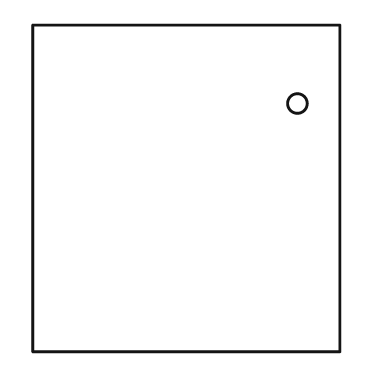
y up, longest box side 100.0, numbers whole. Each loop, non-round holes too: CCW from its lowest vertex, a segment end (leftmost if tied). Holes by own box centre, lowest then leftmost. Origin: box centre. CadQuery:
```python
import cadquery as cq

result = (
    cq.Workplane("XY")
    .moveTo(-47.0, -50.0)
    .lineTo(47.0, -50.0)
    .lineTo(47.0, 50.0)
    .lineTo(-47.0, 50.0)
    .close()
    .moveTo(34.0, 26.0)
    .circle(3.0)
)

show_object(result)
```